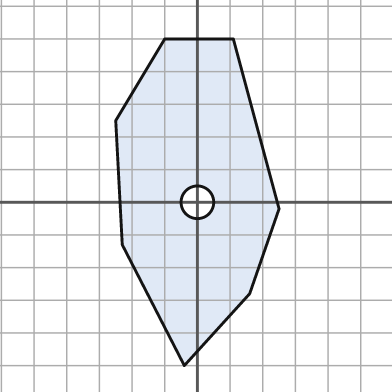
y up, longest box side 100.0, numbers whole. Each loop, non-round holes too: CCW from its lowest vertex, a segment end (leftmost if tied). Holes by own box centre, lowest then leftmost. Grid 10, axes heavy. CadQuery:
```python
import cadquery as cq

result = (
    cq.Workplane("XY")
    .moveTo(-4.0, -50.0)
    .lineTo(16.0, -28.0)
    .lineTo(25.0, -2.0)
    .lineTo(11.0, 50.0)
    .lineTo(-10.0, 50.0)
    .lineTo(-25.0, 25.0)
    .lineTo(-23.0, -13.0)
    .close()
    .moveTo(0.0, 0.0)
    .circle(5.0)
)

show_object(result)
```